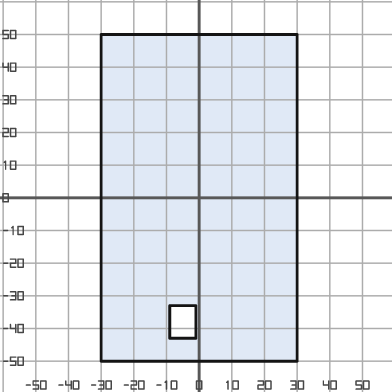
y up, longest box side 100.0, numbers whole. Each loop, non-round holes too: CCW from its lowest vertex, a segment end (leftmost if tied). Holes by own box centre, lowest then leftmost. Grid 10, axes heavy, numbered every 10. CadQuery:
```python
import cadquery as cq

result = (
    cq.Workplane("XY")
    .moveTo(-30.0, -50.0)
    .lineTo(30.0, -50.0)
    .lineTo(30.0, 50.0)
    .lineTo(-30.0, 50.0)
    .close()
    .moveTo(-9.0, -43.0)
    .lineTo(-1.0, -43.0)
    .lineTo(-1.0, -33.0)
    .lineTo(-9.0, -33.0)
    .close()
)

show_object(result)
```